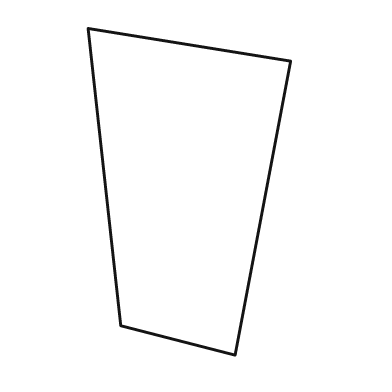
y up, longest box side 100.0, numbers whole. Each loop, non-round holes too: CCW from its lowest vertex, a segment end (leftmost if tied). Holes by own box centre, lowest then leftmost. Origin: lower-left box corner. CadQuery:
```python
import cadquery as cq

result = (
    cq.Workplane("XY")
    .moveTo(45.0, 0.0)
    .lineTo(62.0, 90.0)
    .lineTo(0.0, 100.0)
    .lineTo(10.0, 9.0)
    .close()
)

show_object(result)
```